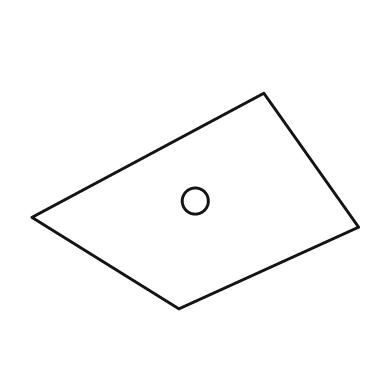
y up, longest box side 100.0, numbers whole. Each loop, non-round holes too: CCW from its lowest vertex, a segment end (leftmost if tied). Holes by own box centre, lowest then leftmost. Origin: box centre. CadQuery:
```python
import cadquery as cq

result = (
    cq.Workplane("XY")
    .moveTo(-5.0, -33.0)
    .lineTo(50.0, -8.0)
    .lineTo(21.0, 33.0)
    .lineTo(-50.0, -5.0)
    .close()
    .moveTo(0.0, 0.0)
    .circle(4.0)
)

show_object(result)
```